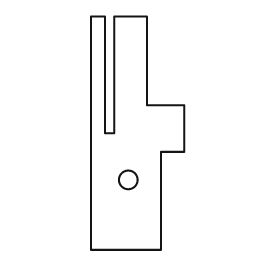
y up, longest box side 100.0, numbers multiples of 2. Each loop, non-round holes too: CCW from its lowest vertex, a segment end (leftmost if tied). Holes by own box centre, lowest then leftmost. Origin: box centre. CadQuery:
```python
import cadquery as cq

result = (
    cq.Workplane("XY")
    .moveTo(-20.0, -50.0)
    .lineTo(10.0, -50.0)
    .lineTo(10.0, -8.0)
    .lineTo(20.0, -8.0)
    .lineTo(20.0, 12.0)
    .lineTo(4.0, 12.0)
    .lineTo(4.0, 50.0)
    .lineTo(-10.0, 50.0)
    .lineTo(-10.0, 0.0)
    .lineTo(-14.0, 0.0)
    .lineTo(-14.0, 50.0)
    .lineTo(-20.0, 50.0)
    .close()
    .moveTo(-4.0, -20.0)
    .circle(4.0)
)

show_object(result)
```